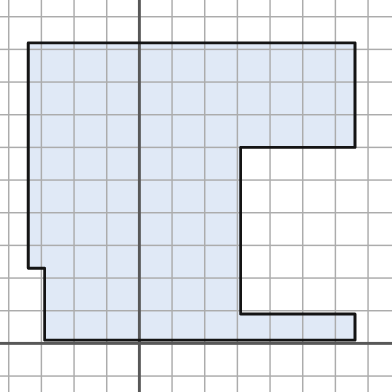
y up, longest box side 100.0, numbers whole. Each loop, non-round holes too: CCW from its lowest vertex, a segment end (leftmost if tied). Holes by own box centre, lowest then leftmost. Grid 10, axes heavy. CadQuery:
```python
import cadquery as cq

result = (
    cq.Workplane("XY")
    .moveTo(-29.0, 1.0)
    .lineTo(66.0, 1.0)
    .lineTo(66.0, 9.0)
    .lineTo(31.0, 9.0)
    .lineTo(31.0, 60.0)
    .lineTo(66.0, 60.0)
    .lineTo(66.0, 92.0)
    .lineTo(-34.0, 92.0)
    .lineTo(-34.0, 23.0)
    .lineTo(-29.0, 23.0)
    .close()
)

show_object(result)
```